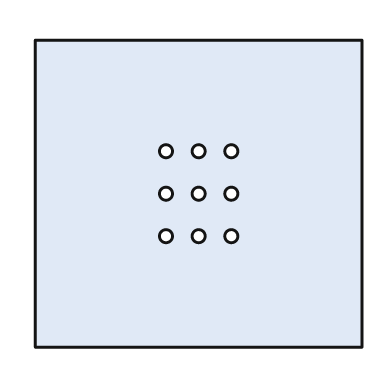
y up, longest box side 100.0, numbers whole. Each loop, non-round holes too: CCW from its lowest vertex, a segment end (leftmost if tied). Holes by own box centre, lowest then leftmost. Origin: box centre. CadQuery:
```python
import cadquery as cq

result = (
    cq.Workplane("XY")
    .moveTo(-50.0, -47.0)
    .lineTo(50.0, -47.0)
    .lineTo(50.0, 47.0)
    .lineTo(-50.0, 47.0)
    .close()
    .moveTo(-10.0, -13.0)
    .circle(2.0)
    .moveTo(0.0, -13.0)
    .circle(2.0)
    .moveTo(10.0, -13.0)
    .circle(2.0)
    .moveTo(-10.0, 0.0)
    .circle(2.0)
    .moveTo(0.0, 0.0)
    .circle(2.0)
    .moveTo(10.0, 0.0)
    .circle(2.0)
    .moveTo(-10.0, 13.0)
    .circle(2.0)
    .moveTo(0.0, 13.0)
    .circle(2.0)
    .moveTo(10.0, 13.0)
    .circle(2.0)
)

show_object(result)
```